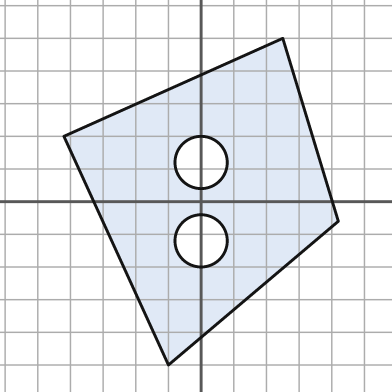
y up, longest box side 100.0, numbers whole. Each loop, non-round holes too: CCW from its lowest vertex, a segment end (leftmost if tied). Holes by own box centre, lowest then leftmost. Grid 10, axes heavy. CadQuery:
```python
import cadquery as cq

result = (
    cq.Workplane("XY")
    .moveTo(-10.0, -50.0)
    .lineTo(42.0, -6.0)
    .lineTo(25.0, 50.0)
    .lineTo(-42.0, 20.0)
    .close()
    .moveTo(0.0, -12.0)
    .circle(8.0)
    .moveTo(0.0, 12.0)
    .circle(8.0)
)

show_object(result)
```